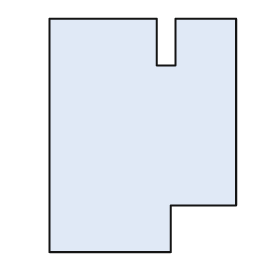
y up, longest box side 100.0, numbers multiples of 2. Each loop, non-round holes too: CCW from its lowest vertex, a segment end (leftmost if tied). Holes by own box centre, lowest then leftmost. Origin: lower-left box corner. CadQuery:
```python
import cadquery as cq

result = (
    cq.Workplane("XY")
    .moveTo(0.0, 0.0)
    .lineTo(52.0, 0.0)
    .lineTo(52.0, 20.0)
    .lineTo(80.0, 20.0)
    .lineTo(80.0, 100.0)
    .lineTo(54.0, 100.0)
    .lineTo(54.0, 80.0)
    .lineTo(46.0, 80.0)
    .lineTo(46.0, 100.0)
    .lineTo(0.0, 100.0)
    .close()
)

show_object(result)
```